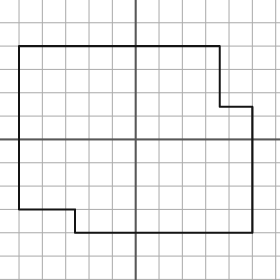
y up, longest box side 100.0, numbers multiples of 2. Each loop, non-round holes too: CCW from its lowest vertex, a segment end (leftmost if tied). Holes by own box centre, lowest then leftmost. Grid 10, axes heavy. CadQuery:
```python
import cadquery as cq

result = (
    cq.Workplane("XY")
    .moveTo(-26.0, -40.0)
    .lineTo(50.0, -40.0)
    .lineTo(50.0, 14.0)
    .lineTo(36.0, 14.0)
    .lineTo(36.0, 40.0)
    .lineTo(-50.0, 40.0)
    .lineTo(-50.0, -30.0)
    .lineTo(-26.0, -30.0)
    .close()
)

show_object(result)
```